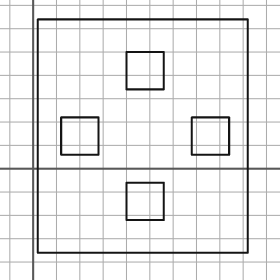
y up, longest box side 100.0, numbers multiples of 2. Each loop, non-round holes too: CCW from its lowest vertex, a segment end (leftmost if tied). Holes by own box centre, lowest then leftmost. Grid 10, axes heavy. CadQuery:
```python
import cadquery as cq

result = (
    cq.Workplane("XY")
    .moveTo(2.0, -36.0)
    .lineTo(92.0, -36.0)
    .lineTo(92.0, 64.0)
    .lineTo(2.0, 64.0)
    .close()
    .moveTo(40.0, -22.0)
    .lineTo(56.0, -22.0)
    .lineTo(56.0, -6.0)
    .lineTo(40.0, -6.0)
    .close()
    .moveTo(12.0, 6.0)
    .lineTo(28.0, 6.0)
    .lineTo(28.0, 22.0)
    .lineTo(12.0, 22.0)
    .close()
    .moveTo(68.0, 6.0)
    .lineTo(84.0, 6.0)
    .lineTo(84.0, 22.0)
    .lineTo(68.0, 22.0)
    .close()
    .moveTo(40.0, 34.0)
    .lineTo(56.0, 34.0)
    .lineTo(56.0, 50.0)
    .lineTo(40.0, 50.0)
    .close()
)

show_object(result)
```